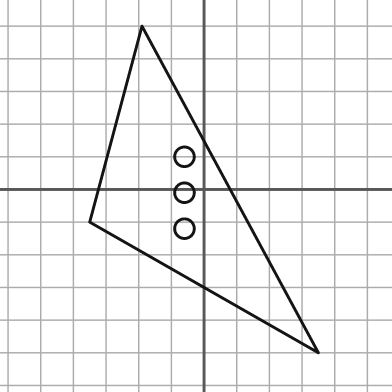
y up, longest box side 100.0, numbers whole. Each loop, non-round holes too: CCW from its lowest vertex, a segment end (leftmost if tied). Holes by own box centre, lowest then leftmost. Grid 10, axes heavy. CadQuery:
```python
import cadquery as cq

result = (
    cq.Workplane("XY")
    .moveTo(35.0, -50.0)
    .lineTo(-19.0, 50.0)
    .lineTo(-35.0, -10.0)
    .close()
    .moveTo(-6.0, -12.0)
    .circle(3.0)
    .moveTo(-6.0, -1.0)
    .circle(3.0)
    .moveTo(-6.0, 10.0)
    .circle(3.0)
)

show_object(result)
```